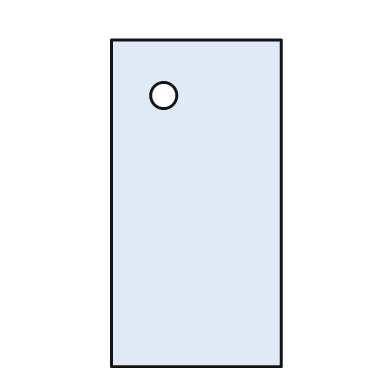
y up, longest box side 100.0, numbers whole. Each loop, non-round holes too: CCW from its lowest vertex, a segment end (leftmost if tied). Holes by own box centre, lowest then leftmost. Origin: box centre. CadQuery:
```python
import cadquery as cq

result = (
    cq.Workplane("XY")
    .moveTo(-26.0, -50.0)
    .lineTo(26.0, -50.0)
    .lineTo(26.0, 50.0)
    .lineTo(-26.0, 50.0)
    .close()
    .moveTo(-10.0, 33.0)
    .circle(4.0)
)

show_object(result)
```